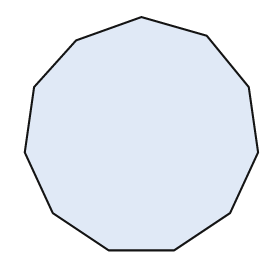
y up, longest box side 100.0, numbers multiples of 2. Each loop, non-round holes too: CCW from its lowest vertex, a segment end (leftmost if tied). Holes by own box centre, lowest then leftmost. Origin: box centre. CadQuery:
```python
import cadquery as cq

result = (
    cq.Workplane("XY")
    .moveTo(-14.0, -50.0)
    .lineTo(14.0, -50.0)
    .lineTo(38.0, -34.0)
    .lineTo(50.0, -8.0)
    .lineTo(46.0, 20.0)
    .lineTo(28.0, 42.0)
    .lineTo(0.0, 50.0)
    .lineTo(-28.0, 40.0)
    .lineTo(-46.0, 20.0)
    .lineTo(-50.0, -8.0)
    .lineTo(-38.0, -34.0)
    .close()
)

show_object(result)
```